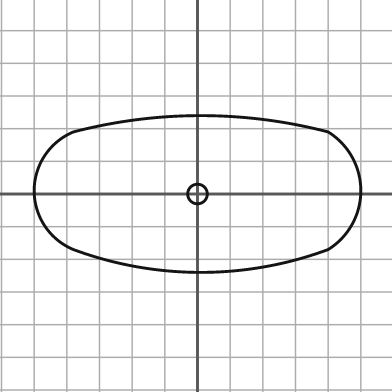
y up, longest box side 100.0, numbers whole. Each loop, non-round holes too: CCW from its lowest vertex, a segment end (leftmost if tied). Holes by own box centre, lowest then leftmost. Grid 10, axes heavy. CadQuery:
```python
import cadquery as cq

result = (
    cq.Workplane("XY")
    .moveTo(-38.0, -17.0)
    .threePointArc((1.0, -24.0), (40.0, -17.0))
    .threePointArc((50.0, 1.0), (40.0, 19.0))
    .threePointArc((1.0, 24.0), (-38.0, 19.0))
    .threePointArc((-50.0, 1.0), (-38.0, -17.0))
    .close()
    .moveTo(0.0, 0.0)
    .circle(3.0)
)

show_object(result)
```